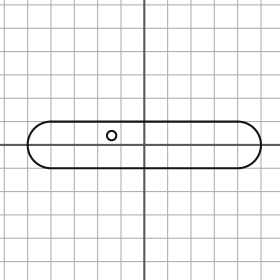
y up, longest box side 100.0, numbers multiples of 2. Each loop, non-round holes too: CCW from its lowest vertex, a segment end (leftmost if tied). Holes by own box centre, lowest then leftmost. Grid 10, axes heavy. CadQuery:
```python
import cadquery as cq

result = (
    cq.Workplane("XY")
    .moveTo(-40.0, -10.0)
    .lineTo(40.0, -10.0)
    .threePointArc((50.0, 0.0), (40.0, 10.0))
    .lineTo(-40.0, 10.0)
    .threePointArc((-50.0, 0.0), (-40.0, -10.0))
    .close()
    .moveTo(-14.0, 4.0)
    .circle(2.0)
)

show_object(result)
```